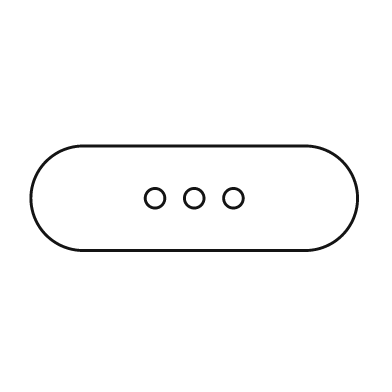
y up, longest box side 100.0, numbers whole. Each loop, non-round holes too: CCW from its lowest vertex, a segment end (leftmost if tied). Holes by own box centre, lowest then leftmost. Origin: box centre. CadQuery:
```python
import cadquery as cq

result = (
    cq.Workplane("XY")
    .moveTo(-34.0, -16.0)
    .lineTo(34.0, -16.0)
    .threePointArc((50.0, 0.0), (34.0, 16.0))
    .lineTo(-34.0, 16.0)
    .threePointArc((-50.0, 0.0), (-34.0, -16.0))
    .close()
    .moveTo(-12.0, 0.0)
    .circle(3.0)
    .moveTo(0.0, 0.0)
    .circle(3.0)
    .moveTo(12.0, 0.0)
    .circle(3.0)
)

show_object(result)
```